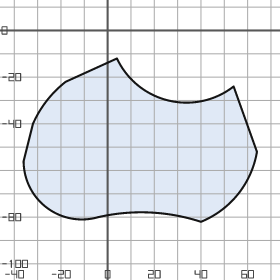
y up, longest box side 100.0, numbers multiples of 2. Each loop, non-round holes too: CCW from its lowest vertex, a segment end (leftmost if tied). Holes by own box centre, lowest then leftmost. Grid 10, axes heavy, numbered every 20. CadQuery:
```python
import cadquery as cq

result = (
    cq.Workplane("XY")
    .moveTo(40.0, -82.0)
    .threePointArc((56.0, -70.0), (64.0, -52.0))
    .lineTo(54.0, -24.0)
    .threePointArc((26.0, -30.0), (4.0, -12.0))
    .lineTo(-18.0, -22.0)
    .threePointArc((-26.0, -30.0), (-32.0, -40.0))
    .lineTo(-36.0, -56.0)
    .threePointArc((-26.0, -76.0), (-4.0, -80.0))
    .threePointArc((18.0, -78.0), (40.0, -82.0))
    .close()
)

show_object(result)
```